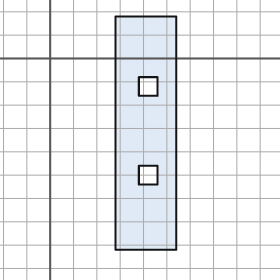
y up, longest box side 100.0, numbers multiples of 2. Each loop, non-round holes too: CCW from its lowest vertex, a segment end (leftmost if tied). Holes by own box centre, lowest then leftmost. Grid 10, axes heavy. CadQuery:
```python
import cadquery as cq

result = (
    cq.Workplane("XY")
    .moveTo(28.0, -82.0)
    .lineTo(54.0, -82.0)
    .lineTo(54.0, 18.0)
    .lineTo(28.0, 18.0)
    .close()
    .moveTo(38.0, -54.0)
    .lineTo(46.0, -54.0)
    .lineTo(46.0, -46.0)
    .lineTo(38.0, -46.0)
    .close()
    .moveTo(38.0, -16.0)
    .lineTo(46.0, -16.0)
    .lineTo(46.0, -8.0)
    .lineTo(38.0, -8.0)
    .close()
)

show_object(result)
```